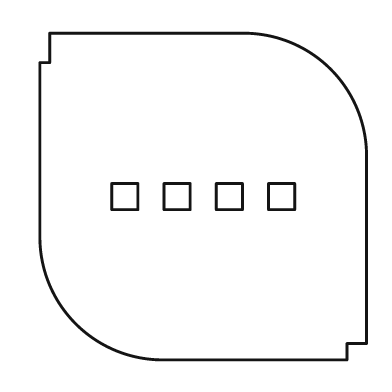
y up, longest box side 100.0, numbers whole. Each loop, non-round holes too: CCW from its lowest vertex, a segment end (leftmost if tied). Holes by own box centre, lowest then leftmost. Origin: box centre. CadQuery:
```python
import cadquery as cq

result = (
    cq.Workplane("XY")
    .moveTo(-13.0, -50.0)
    .lineTo(44.0, -50.0)
    .lineTo(44.0, -45.0)
    .lineTo(50.0, -45.0)
    .lineTo(50.0, 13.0)
    .threePointArc((39.0, 39.0), (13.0, 50.0))
    .lineTo(-47.0, 50.0)
    .lineTo(-47.0, 41.0)
    .lineTo(-50.0, 41.0)
    .lineTo(-50.0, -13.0)
    .threePointArc((-39.0, -39.0), (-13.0, -50.0))
    .close()
    .moveTo(-28.0, -4.0)
    .lineTo(-20.0, -4.0)
    .lineTo(-20.0, 4.0)
    .lineTo(-28.0, 4.0)
    .close()
    .moveTo(-12.0, -4.0)
    .lineTo(-4.0, -4.0)
    .lineTo(-4.0, 4.0)
    .lineTo(-12.0, 4.0)
    .close()
    .moveTo(4.0, -4.0)
    .lineTo(12.0, -4.0)
    .lineTo(12.0, 4.0)
    .lineTo(4.0, 4.0)
    .close()
    .moveTo(20.0, -4.0)
    .lineTo(28.0, -4.0)
    .lineTo(28.0, 4.0)
    .lineTo(20.0, 4.0)
    .close()
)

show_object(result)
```